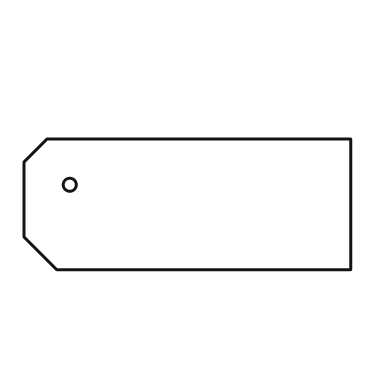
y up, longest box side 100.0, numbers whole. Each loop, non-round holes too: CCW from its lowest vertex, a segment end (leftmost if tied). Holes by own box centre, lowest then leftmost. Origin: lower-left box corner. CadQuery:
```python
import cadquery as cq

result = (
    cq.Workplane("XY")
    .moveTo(10.0, 0.0)
    .lineTo(100.0, 0.0)
    .lineTo(100.0, 40.0)
    .lineTo(7.0, 40.0)
    .lineTo(0.0, 33.0)
    .lineTo(0.0, 10.0)
    .close()
    .moveTo(14.0, 26.0)
    .circle(2.0)
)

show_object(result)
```